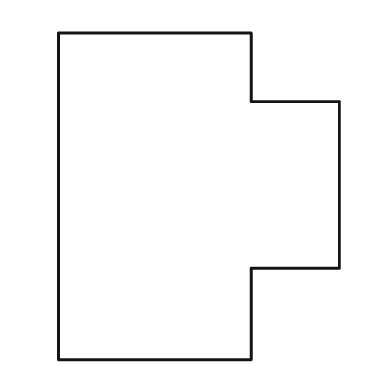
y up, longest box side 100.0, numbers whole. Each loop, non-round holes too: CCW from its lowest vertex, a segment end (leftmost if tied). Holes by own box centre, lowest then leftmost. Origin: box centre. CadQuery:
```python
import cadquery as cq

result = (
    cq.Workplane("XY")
    .moveTo(-43.0, -50.0)
    .lineTo(16.0, -50.0)
    .lineTo(16.0, -22.0)
    .lineTo(43.0, -22.0)
    .lineTo(43.0, 29.0)
    .lineTo(16.0, 29.0)
    .lineTo(16.0, 50.0)
    .lineTo(-43.0, 50.0)
    .close()
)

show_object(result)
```